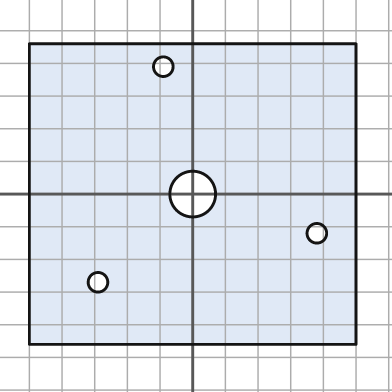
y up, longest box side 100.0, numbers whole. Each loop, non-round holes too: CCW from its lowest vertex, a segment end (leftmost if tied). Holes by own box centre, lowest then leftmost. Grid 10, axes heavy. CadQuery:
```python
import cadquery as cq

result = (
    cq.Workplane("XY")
    .moveTo(-50.0, -46.0)
    .lineTo(50.0, -46.0)
    .lineTo(50.0, 46.0)
    .lineTo(-50.0, 46.0)
    .close()
    .moveTo(-29.0, -27.0)
    .circle(3.0)
    .moveTo(38.0, -12.0)
    .circle(3.0)
    .moveTo(0.0, 0.0)
    .circle(7.0)
    .moveTo(-9.0, 39.0)
    .circle(3.0)
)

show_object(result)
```